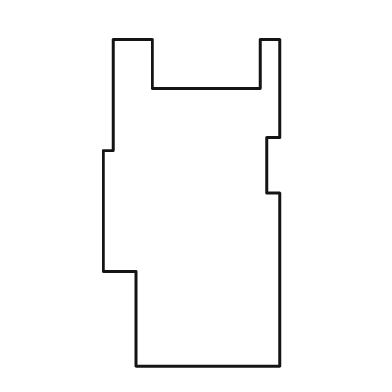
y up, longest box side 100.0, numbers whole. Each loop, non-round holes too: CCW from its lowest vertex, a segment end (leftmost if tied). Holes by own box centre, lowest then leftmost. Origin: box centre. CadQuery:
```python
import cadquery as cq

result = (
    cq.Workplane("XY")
    .moveTo(-17.0, -50.0)
    .lineTo(27.0, -50.0)
    .lineTo(27.0, 3.0)
    .lineTo(23.0, 3.0)
    .lineTo(23.0, 20.0)
    .lineTo(27.0, 20.0)
    .lineTo(27.0, 50.0)
    .lineTo(21.0, 50.0)
    .lineTo(21.0, 35.0)
    .lineTo(-12.0, 35.0)
    .lineTo(-12.0, 50.0)
    .lineTo(-24.0, 50.0)
    .lineTo(-24.0, 16.0)
    .lineTo(-27.0, 16.0)
    .lineTo(-27.0, -21.0)
    .lineTo(-17.0, -21.0)
    .close()
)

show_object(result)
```